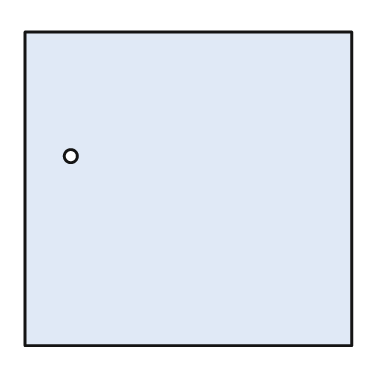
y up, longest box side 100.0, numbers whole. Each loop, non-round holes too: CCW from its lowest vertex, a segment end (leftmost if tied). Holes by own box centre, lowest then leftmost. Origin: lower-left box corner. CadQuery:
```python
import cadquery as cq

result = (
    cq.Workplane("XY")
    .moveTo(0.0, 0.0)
    .lineTo(100.0, 0.0)
    .lineTo(100.0, 96.0)
    .lineTo(0.0, 96.0)
    .close()
    .moveTo(14.0, 58.0)
    .circle(2.0)
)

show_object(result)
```